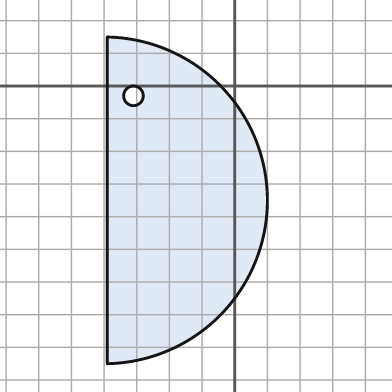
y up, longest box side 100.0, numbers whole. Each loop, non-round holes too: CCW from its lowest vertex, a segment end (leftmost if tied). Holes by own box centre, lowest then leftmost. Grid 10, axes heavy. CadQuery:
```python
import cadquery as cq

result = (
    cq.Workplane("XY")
    .moveTo(-39.0, -85.0)
    .threePointArc((10.0, -35.0), (-39.0, 15.0))
    .close()
    .moveTo(-31.0, -3.0)
    .circle(3.0)
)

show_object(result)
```